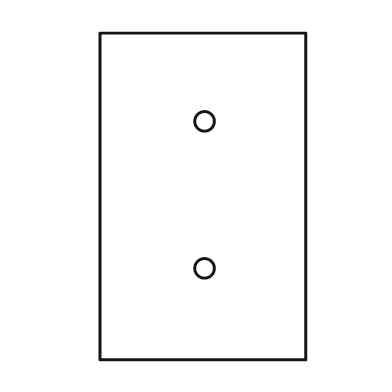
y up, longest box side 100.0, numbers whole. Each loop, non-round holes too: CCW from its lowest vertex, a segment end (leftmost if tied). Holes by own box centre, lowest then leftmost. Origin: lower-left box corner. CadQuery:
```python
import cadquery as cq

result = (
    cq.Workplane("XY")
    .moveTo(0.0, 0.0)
    .lineTo(63.0, 0.0)
    .lineTo(63.0, 100.0)
    .lineTo(0.0, 100.0)
    .close()
    .moveTo(32.0, 28.0)
    .circle(3.0)
    .moveTo(32.0, 73.0)
    .circle(3.0)
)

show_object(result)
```